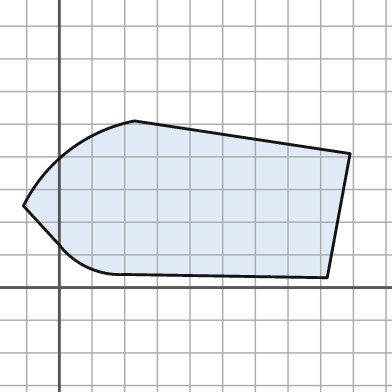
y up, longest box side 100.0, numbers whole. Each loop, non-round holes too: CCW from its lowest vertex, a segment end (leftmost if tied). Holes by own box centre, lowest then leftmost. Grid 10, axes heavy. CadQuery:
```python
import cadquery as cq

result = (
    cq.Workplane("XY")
    .moveTo(82.0, 3.0)
    .lineTo(89.0, 41.0)
    .lineTo(23.0, 51.0)
    .threePointArc((3.0, 42.0), (-11.0, 25.0))
    .lineTo(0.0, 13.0)
    .threePointArc((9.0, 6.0), (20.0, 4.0))
    .close()
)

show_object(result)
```